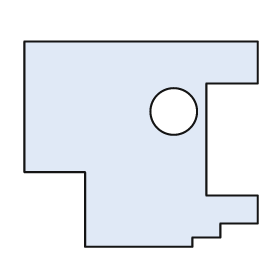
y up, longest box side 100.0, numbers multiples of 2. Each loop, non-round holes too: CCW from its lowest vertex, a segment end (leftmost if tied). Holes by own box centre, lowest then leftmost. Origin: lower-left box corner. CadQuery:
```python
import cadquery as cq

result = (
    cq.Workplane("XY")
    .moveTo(26.0, 0.0)
    .lineTo(72.0, 0.0)
    .lineTo(72.0, 4.0)
    .lineTo(84.0, 4.0)
    .lineTo(84.0, 10.0)
    .lineTo(100.0, 10.0)
    .lineTo(100.0, 22.0)
    .lineTo(78.0, 22.0)
    .lineTo(78.0, 70.0)
    .lineTo(100.0, 70.0)
    .lineTo(100.0, 88.0)
    .lineTo(0.0, 88.0)
    .lineTo(0.0, 32.0)
    .lineTo(26.0, 32.0)
    .close()
    .moveTo(64.0, 58.0)
    .circle(10.0)
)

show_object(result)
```